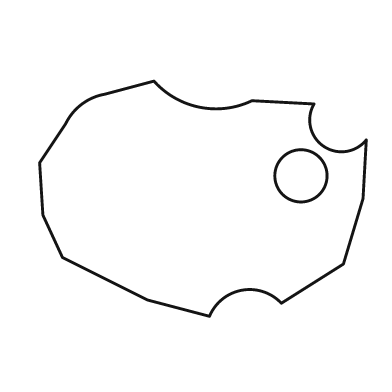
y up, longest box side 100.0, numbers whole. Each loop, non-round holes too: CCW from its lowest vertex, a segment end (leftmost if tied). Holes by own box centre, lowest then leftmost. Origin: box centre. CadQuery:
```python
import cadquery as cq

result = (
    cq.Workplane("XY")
    .moveTo(2.0, -36.0)
    .threePointArc((12.0, -28.0), (24.0, -32.0))
    .lineTo(43.0, -20.0)
    .lineTo(49.0, 0.0)
    .lineTo(50.0, 18.0)
    .threePointArc((37.0, 16.0), (34.0, 29.0))
    .lineTo(15.0, 30.0)
    .threePointArc((-1.0, 28.0), (-15.0, 36.0))
    .lineTo(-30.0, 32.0)
    .threePointArc((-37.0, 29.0), (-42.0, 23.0))
    .lineTo(-50.0, 11.0)
    .lineTo(-49.0, -5.0)
    .lineTo(-43.0, -18.0)
    .lineTo(-17.0, -31.0)
    .close()
    .moveTo(30.0, 7.0)
    .circle(8.0)
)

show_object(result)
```